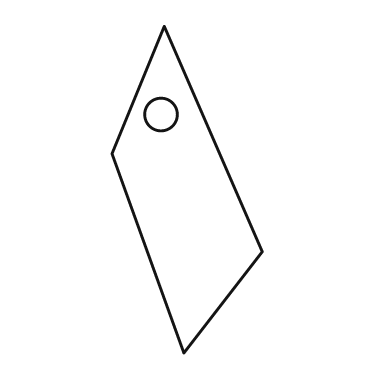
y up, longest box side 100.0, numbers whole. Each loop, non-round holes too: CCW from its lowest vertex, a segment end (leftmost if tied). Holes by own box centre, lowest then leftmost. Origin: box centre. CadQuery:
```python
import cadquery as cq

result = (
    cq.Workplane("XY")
    .moveTo(-1.0, -50.0)
    .lineTo(23.0, -19.0)
    .lineTo(-7.0, 50.0)
    .lineTo(-23.0, 11.0)
    .close()
    .moveTo(-8.0, 23.0)
    .circle(5.0)
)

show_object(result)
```